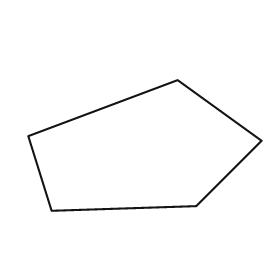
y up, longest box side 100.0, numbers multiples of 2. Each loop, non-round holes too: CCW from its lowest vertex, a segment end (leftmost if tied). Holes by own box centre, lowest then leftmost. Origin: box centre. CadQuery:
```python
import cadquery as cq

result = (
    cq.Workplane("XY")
    .moveTo(-40.0, -28.0)
    .lineTo(22.0, -26.0)
    .lineTo(50.0, 2.0)
    .lineTo(14.0, 28.0)
    .lineTo(-50.0, 4.0)
    .close()
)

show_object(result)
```